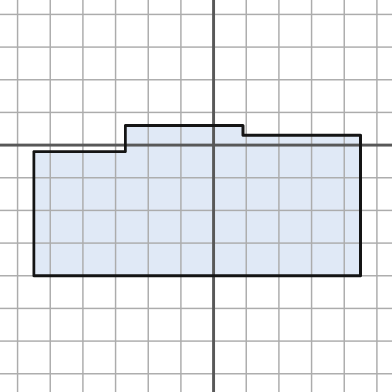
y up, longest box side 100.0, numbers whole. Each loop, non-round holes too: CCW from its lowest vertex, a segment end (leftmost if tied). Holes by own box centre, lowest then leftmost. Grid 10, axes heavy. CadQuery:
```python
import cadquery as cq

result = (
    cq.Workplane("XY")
    .moveTo(-55.0, -40.0)
    .lineTo(45.0, -40.0)
    .lineTo(45.0, 3.0)
    .lineTo(9.0, 3.0)
    .lineTo(9.0, 6.0)
    .lineTo(-27.0, 6.0)
    .lineTo(-27.0, -2.0)
    .lineTo(-55.0, -2.0)
    .close()
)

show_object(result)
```